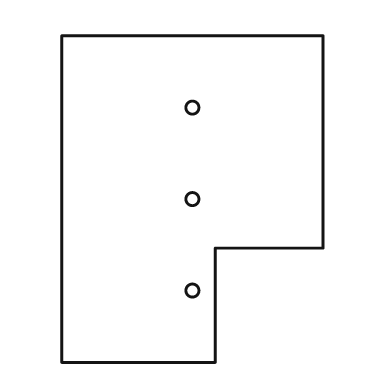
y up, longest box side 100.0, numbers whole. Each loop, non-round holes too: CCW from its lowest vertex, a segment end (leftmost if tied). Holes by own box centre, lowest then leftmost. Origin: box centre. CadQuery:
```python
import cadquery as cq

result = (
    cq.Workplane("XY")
    .moveTo(-40.0, -50.0)
    .lineTo(7.0, -50.0)
    .lineTo(7.0, -15.0)
    .lineTo(40.0, -15.0)
    .lineTo(40.0, 50.0)
    .lineTo(-40.0, 50.0)
    .close()
    .moveTo(0.0, -28.0)
    .circle(2.0)
    .moveTo(0.0, 0.0)
    .circle(2.0)
    .moveTo(0.0, 28.0)
    .circle(2.0)
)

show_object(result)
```